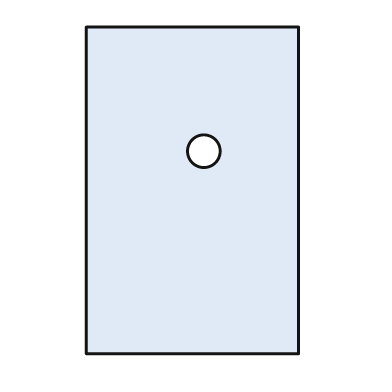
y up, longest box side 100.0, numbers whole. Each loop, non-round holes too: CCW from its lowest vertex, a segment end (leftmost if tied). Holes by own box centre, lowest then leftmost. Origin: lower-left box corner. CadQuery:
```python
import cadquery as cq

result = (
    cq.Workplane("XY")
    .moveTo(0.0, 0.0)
    .lineTo(65.0, 0.0)
    .lineTo(65.0, 100.0)
    .lineTo(0.0, 100.0)
    .close()
    .moveTo(36.0, 62.0)
    .circle(5.0)
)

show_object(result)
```